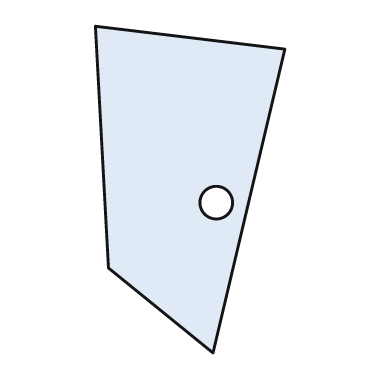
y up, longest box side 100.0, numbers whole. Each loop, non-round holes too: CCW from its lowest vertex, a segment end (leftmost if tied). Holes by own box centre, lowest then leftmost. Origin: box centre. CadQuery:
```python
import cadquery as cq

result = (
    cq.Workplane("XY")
    .moveTo(7.0, -50.0)
    .lineTo(29.0, 43.0)
    .lineTo(-29.0, 50.0)
    .lineTo(-25.0, -24.0)
    .close()
    .moveTo(8.0, -4.0)
    .circle(5.0)
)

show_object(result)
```